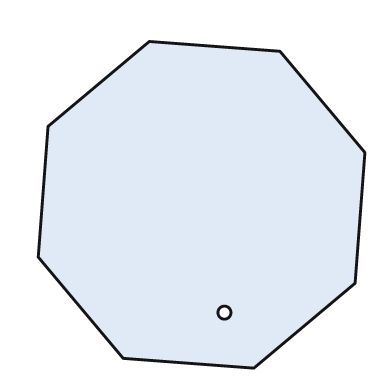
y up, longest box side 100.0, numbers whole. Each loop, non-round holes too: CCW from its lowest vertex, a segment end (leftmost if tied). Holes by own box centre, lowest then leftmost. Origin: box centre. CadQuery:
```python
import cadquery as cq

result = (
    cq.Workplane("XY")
    .moveTo(16.0, -50.0)
    .lineTo(47.0, -24.0)
    .lineTo(50.0, 16.0)
    .lineTo(24.0, 47.0)
    .lineTo(-16.0, 50.0)
    .lineTo(-47.0, 24.0)
    .lineTo(-50.0, -16.0)
    .lineTo(-24.0, -47.0)
    .close()
    .moveTo(7.0, -33.0)
    .circle(2.0)
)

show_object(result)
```